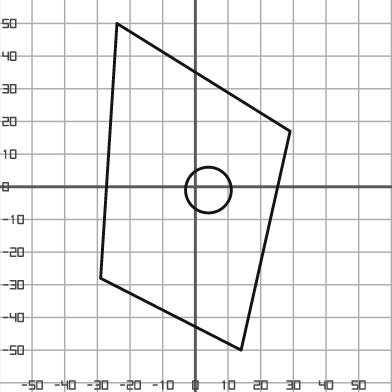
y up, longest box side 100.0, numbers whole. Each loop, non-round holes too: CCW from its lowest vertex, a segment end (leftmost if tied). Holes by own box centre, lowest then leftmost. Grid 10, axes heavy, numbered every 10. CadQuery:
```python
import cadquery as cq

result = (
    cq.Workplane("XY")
    .moveTo(14.0, -50.0)
    .lineTo(29.0, 17.0)
    .lineTo(-24.0, 50.0)
    .lineTo(-29.0, -28.0)
    .close()
    .moveTo(4.0, -1.0)
    .circle(7.0)
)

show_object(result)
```